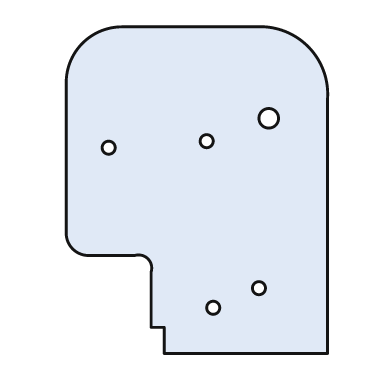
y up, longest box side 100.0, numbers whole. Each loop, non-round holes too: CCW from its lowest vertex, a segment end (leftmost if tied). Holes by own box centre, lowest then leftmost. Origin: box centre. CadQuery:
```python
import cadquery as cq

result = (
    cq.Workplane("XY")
    .moveTo(-10.0, -50.0)
    .lineTo(40.0, -50.0)
    .lineTo(40.0, 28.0)
    .threePointArc((34.0, 44.0), (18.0, 50.0))
    .lineTo(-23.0, 50.0)
    .threePointArc((-35.0, 45.0), (-40.0, 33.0))
    .lineTo(-40.0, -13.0)
    .threePointArc((-38.0, -18.0), (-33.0, -20.0))
    .lineTo(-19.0, -20.0)
    .threePointArc((-15.0, -21.0), (-14.0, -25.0))
    .lineTo(-14.0, -42.0)
    .lineTo(-10.0, -42.0)
    .close()
    .moveTo(5.0, -36.0)
    .circle(2.0)
    .moveTo(19.0, -30.0)
    .circle(2.0)
    .moveTo(-27.0, 13.0)
    .circle(2.0)
    .moveTo(3.0, 15.0)
    .circle(2.0)
    .moveTo(22.0, 22.0)
    .circle(3.0)
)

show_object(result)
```